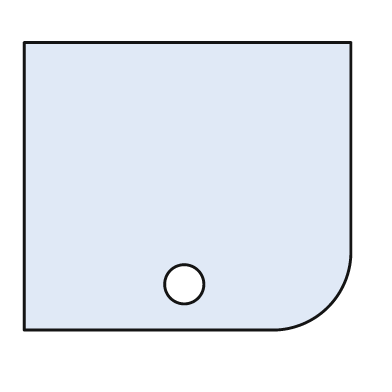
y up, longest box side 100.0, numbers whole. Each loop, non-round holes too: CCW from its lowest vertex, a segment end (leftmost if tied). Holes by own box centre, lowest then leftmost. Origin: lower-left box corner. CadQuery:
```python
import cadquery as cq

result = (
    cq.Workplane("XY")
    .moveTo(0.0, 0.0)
    .lineTo(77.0, 0.0)
    .threePointArc((93.0, 7.0), (100.0, 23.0))
    .lineTo(100.0, 88.0)
    .lineTo(0.0, 88.0)
    .close()
    .moveTo(49.0, 14.0)
    .circle(6.0)
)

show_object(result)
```